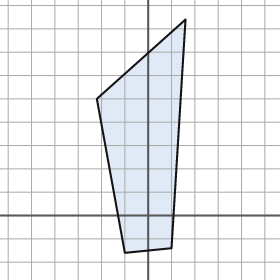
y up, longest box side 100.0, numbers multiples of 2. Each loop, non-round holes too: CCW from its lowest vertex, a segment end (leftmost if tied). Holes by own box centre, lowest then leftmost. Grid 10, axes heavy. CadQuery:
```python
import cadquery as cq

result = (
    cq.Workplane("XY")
    .moveTo(-10.0, -16.0)
    .lineTo(10.0, -14.0)
    .lineTo(16.0, 84.0)
    .lineTo(-22.0, 50.0)
    .close()
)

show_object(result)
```